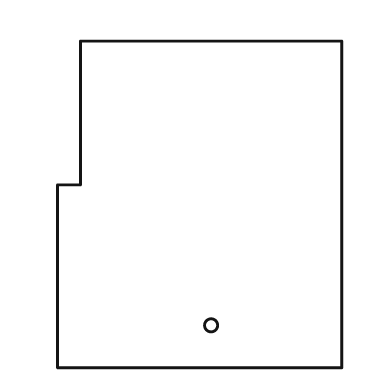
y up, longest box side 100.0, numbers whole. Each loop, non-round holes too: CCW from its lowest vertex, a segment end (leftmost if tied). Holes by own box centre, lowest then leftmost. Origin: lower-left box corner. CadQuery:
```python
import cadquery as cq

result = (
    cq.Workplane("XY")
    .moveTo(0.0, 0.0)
    .lineTo(87.0, 0.0)
    .lineTo(87.0, 100.0)
    .lineTo(7.0, 100.0)
    .lineTo(7.0, 56.0)
    .lineTo(0.0, 56.0)
    .close()
    .moveTo(47.0, 13.0)
    .circle(2.0)
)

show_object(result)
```